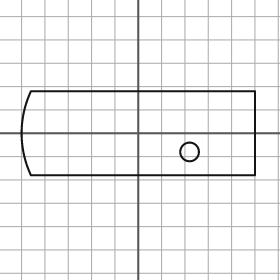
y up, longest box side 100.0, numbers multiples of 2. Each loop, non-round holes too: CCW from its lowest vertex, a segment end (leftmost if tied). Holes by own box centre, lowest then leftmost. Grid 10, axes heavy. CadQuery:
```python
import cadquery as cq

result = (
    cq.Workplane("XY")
    .moveTo(-46.0, -18.0)
    .lineTo(50.0, -18.0)
    .lineTo(50.0, 18.0)
    .lineTo(-46.0, 18.0)
    .threePointArc((-50.0, 0.0), (-46.0, -18.0))
    .close()
    .moveTo(22.0, -8.0)
    .circle(4.0)
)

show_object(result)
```